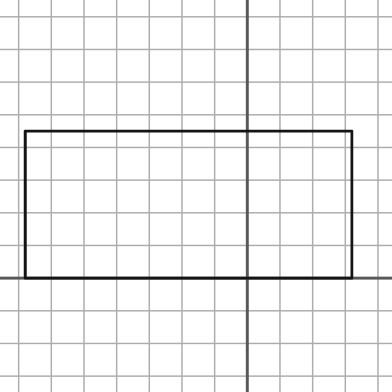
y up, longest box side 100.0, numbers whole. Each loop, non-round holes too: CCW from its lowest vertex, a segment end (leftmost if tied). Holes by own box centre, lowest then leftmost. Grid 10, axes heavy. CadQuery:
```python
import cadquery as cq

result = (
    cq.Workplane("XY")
    .moveTo(-68.0, 0.0)
    .lineTo(32.0, 0.0)
    .lineTo(32.0, 45.0)
    .lineTo(-68.0, 45.0)
    .close()
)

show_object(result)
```